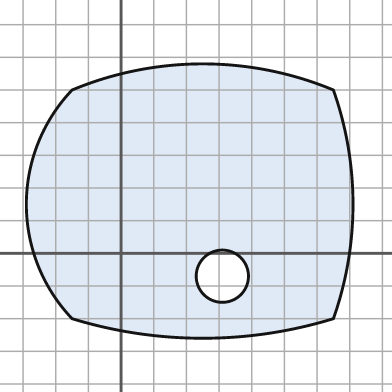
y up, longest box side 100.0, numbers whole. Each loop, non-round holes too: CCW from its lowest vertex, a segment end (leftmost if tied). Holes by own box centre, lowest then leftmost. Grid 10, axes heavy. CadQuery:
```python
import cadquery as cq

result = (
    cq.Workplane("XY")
    .moveTo(-15.0, -20.0)
    .threePointArc((25.0, -26.0), (65.0, -20.0))
    .threePointArc((71.0, 15.0), (65.0, 50.0))
    .threePointArc((25.0, 58.0), (-15.0, 50.0))
    .threePointArc((-29.0, 15.0), (-15.0, -20.0))
    .close()
    .moveTo(31.0, -7.0)
    .circle(8.0)
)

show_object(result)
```